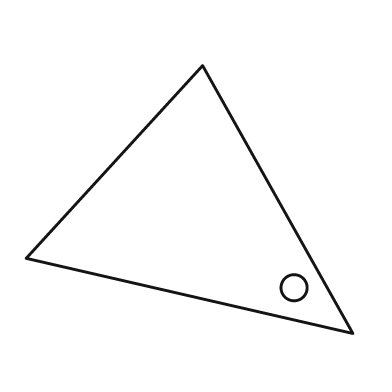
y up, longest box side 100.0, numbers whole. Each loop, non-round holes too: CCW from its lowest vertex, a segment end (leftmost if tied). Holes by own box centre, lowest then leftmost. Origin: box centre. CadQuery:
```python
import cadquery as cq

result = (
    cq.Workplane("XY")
    .moveTo(50.0, -41.0)
    .lineTo(4.0, 41.0)
    .lineTo(-50.0, -18.0)
    .close()
    .moveTo(32.0, -27.0)
    .circle(4.0)
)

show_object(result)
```